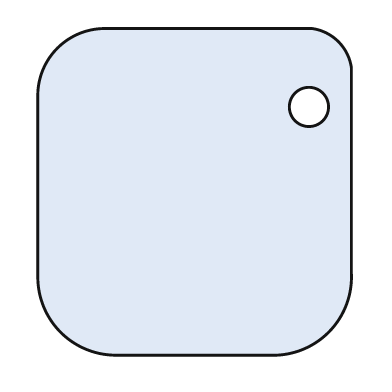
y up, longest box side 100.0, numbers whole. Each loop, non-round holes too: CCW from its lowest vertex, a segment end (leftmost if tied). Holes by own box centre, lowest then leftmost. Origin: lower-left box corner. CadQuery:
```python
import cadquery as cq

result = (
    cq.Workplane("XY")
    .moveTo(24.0, 0.0)
    .lineTo(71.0, 0.0)
    .threePointArc((89.0, 7.0), (96.0, 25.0))
    .lineTo(96.0, 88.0)
    .threePointArc((92.0, 96.0), (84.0, 100.0))
    .lineTo(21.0, 100.0)
    .threePointArc((6.0, 94.0), (0.0, 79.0))
    .lineTo(0.0, 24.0)
    .threePointArc((7.0, 7.0), (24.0, 0.0))
    .close()
    .moveTo(83.0, 76.0)
    .circle(6.0)
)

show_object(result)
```